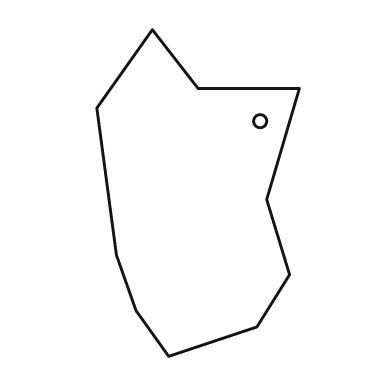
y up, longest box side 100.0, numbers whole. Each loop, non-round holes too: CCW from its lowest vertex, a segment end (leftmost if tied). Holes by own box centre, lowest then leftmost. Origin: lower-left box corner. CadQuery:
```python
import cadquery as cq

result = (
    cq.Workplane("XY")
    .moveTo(22.0, 0.0)
    .lineTo(49.0, 9.0)
    .lineTo(59.0, 25.0)
    .lineTo(52.0, 48.0)
    .lineTo(62.0, 82.0)
    .lineTo(31.0, 82.0)
    .lineTo(17.0, 100.0)
    .lineTo(0.0, 76.0)
    .lineTo(6.0, 31.0)
    .lineTo(12.0, 14.0)
    .close()
    .moveTo(50.0, 72.0)
    .circle(2.0)
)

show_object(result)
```